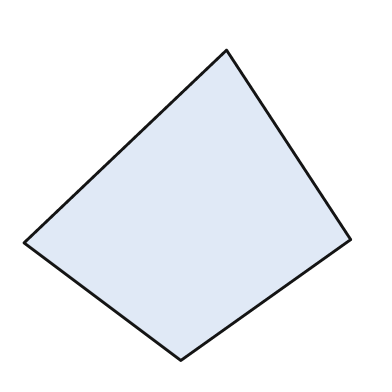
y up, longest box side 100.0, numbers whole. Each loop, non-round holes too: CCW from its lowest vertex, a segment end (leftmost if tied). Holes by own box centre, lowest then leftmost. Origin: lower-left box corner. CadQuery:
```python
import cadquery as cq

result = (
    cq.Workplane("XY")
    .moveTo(48.0, 0.0)
    .lineTo(100.0, 37.0)
    .lineTo(62.0, 95.0)
    .lineTo(0.0, 36.0)
    .close()
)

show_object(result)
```